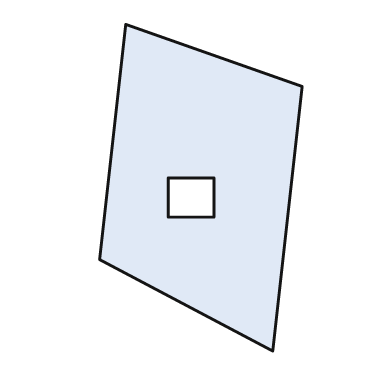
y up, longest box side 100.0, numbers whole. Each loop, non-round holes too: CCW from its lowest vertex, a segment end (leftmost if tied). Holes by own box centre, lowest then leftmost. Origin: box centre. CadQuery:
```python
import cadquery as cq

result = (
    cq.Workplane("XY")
    .moveTo(22.0, -50.0)
    .lineTo(31.0, 31.0)
    .lineTo(-23.0, 50.0)
    .lineTo(-31.0, -22.0)
    .close()
    .moveTo(-10.0, -9.0)
    .lineTo(4.0, -9.0)
    .lineTo(4.0, 3.0)
    .lineTo(-10.0, 3.0)
    .close()
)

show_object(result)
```